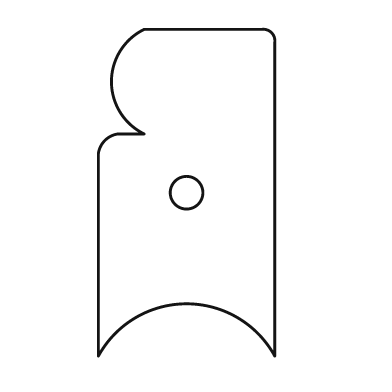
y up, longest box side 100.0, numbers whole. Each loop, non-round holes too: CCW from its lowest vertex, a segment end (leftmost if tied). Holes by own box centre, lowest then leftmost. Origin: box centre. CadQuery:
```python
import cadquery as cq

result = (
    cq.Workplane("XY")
    .moveTo(-27.0, -50.0)
    .threePointArc((0.0, -34.0), (27.0, -50.0))
    .lineTo(27.0, 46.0)
    .threePointArc((26.0, 49.0), (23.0, 50.0))
    .lineTo(-13.0, 50.0)
    .threePointArc((-23.0, 34.0), (-13.0, 18.0))
    .lineTo(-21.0, 18.0)
    .threePointArc((-25.0, 16.0), (-27.0, 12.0))
    .close()
    .moveTo(0.0, 0.0)
    .circle(5.0)
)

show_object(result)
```